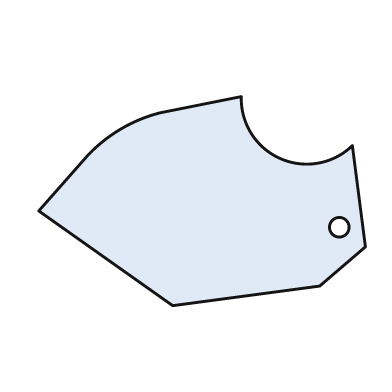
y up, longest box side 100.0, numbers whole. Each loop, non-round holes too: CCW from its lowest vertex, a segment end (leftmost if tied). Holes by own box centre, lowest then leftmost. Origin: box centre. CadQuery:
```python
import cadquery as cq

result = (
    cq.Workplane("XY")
    .moveTo(-9.0, -32.0)
    .lineTo(36.0, -26.0)
    .lineTo(50.0, -14.0)
    .lineTo(46.0, 17.0)
    .threePointArc((24.0, 13.0), (12.0, 32.0))
    .lineTo(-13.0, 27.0)
    .threePointArc((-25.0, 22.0), (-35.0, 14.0))
    .lineTo(-50.0, -3.0)
    .close()
    .moveTo(42.0, -8.0)
    .circle(3.0)
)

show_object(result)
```